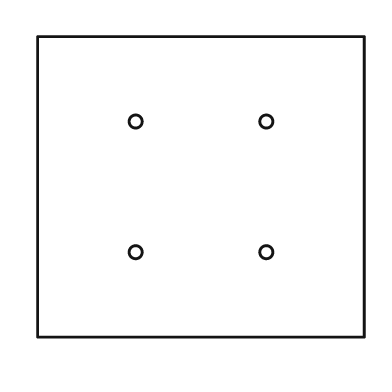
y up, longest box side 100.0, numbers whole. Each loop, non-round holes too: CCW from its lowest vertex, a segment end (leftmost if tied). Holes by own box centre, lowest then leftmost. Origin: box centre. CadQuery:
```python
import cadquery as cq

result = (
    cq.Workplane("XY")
    .moveTo(-50.0, -46.0)
    .lineTo(50.0, -46.0)
    .lineTo(50.0, 46.0)
    .lineTo(-50.0, 46.0)
    .close()
    .moveTo(-20.0, -20.0)
    .circle(2.0)
    .moveTo(20.0, -20.0)
    .circle(2.0)
    .moveTo(-20.0, 20.0)
    .circle(2.0)
    .moveTo(20.0, 20.0)
    .circle(2.0)
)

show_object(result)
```